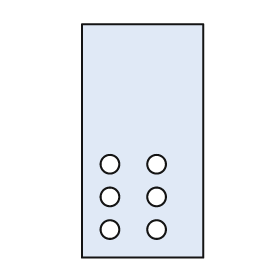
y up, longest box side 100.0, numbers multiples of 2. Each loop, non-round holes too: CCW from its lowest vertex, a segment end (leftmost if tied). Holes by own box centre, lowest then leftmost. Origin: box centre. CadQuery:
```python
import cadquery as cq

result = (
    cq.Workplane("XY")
    .moveTo(-26.0, -50.0)
    .lineTo(26.0, -50.0)
    .lineTo(26.0, 50.0)
    .lineTo(-26.0, 50.0)
    .close()
    .moveTo(-14.0, -38.0)
    .circle(4.0)
    .moveTo(6.0, -38.0)
    .circle(4.0)
    .moveTo(-14.0, -24.0)
    .circle(4.0)
    .moveTo(6.0, -24.0)
    .circle(4.0)
    .moveTo(-14.0, -10.0)
    .circle(4.0)
    .moveTo(6.0, -10.0)
    .circle(4.0)
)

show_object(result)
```